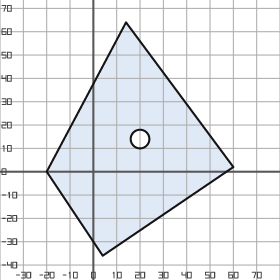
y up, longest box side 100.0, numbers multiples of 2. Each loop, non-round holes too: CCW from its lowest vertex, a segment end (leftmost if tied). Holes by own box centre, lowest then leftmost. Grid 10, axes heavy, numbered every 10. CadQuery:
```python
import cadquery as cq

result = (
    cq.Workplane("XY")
    .moveTo(4.0, -36.0)
    .lineTo(60.0, 2.0)
    .lineTo(14.0, 64.0)
    .lineTo(-20.0, 0.0)
    .close()
    .moveTo(20.0, 14.0)
    .circle(4.0)
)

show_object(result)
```